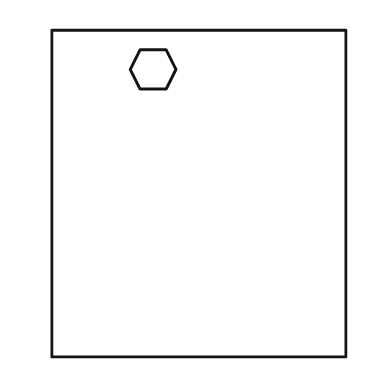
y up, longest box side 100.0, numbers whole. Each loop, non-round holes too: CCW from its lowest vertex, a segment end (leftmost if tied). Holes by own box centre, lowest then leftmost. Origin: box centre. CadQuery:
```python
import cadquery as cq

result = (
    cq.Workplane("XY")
    .moveTo(-45.0, -50.0)
    .lineTo(45.0, -50.0)
    .lineTo(45.0, 50.0)
    .lineTo(-45.0, 50.0)
    .close()
    .moveTo(-18.0, 32.0)
    .lineTo(-10.0, 32.0)
    .lineTo(-7.0, 38.0)
    .lineTo(-10.0, 44.0)
    .lineTo(-18.0, 44.0)
    .lineTo(-21.0, 38.0)
    .close()
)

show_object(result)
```